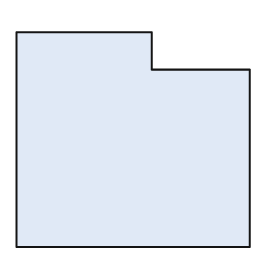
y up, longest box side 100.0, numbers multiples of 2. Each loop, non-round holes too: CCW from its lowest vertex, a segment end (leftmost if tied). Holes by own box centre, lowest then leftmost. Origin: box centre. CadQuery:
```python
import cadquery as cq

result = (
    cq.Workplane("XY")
    .moveTo(-50.0, -46.0)
    .lineTo(50.0, -46.0)
    .lineTo(50.0, 30.0)
    .lineTo(8.0, 30.0)
    .lineTo(8.0, 46.0)
    .lineTo(-50.0, 46.0)
    .close()
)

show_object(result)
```